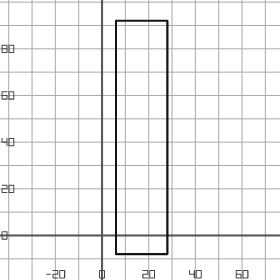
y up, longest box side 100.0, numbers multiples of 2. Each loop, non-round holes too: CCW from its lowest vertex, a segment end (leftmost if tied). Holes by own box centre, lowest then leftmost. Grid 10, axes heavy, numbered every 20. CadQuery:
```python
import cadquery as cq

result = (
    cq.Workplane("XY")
    .moveTo(6.0, -8.0)
    .lineTo(28.0, -8.0)
    .lineTo(28.0, 92.0)
    .lineTo(6.0, 92.0)
    .close()
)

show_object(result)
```